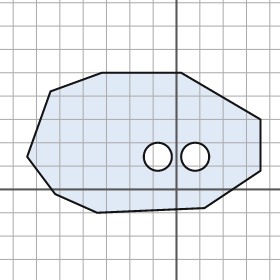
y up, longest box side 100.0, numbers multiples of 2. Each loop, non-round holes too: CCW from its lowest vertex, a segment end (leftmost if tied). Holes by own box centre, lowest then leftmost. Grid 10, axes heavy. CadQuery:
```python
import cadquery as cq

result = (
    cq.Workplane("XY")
    .moveTo(-34.0, -10.0)
    .lineTo(12.0, -8.0)
    .lineTo(36.0, 8.0)
    .lineTo(36.0, 30.0)
    .lineTo(2.0, 50.0)
    .lineTo(-32.0, 50.0)
    .lineTo(-54.0, 42.0)
    .lineTo(-64.0, 14.0)
    .lineTo(-52.0, -2.0)
    .close()
    .moveTo(-8.0, 14.0)
    .circle(6.0)
    .moveTo(8.0, 14.0)
    .circle(6.0)
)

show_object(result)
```